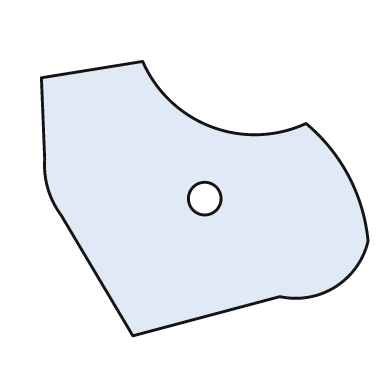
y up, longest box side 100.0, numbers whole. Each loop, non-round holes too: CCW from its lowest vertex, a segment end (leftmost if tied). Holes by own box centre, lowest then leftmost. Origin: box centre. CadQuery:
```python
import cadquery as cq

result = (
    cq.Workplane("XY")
    .moveTo(-22.0, -42.0)
    .lineTo(23.0, -30.0)
    .threePointArc((40.0, -27.0), (50.0, -13.0))
    .threePointArc((44.0, 7.0), (31.0, 23.0))
    .threePointArc((2.0, 22.0), (-19.0, 42.0))
    .lineTo(-50.0, 37.0)
    .lineTo(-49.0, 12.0)
    .threePointArc((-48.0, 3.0), (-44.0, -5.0))
    .close()
    .moveTo(0.0, 0.0)
    .circle(5.0)
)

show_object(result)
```